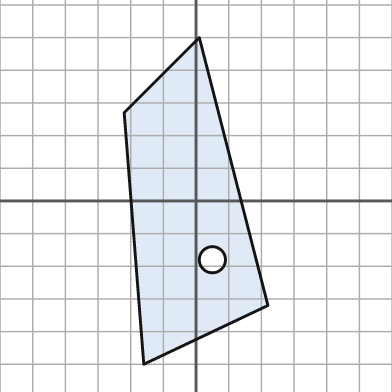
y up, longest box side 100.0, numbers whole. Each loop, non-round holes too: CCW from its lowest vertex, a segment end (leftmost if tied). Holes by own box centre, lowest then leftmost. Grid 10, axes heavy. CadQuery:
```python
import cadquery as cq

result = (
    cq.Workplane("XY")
    .moveTo(-16.0, -50.0)
    .lineTo(22.0, -32.0)
    .lineTo(1.0, 50.0)
    .lineTo(-22.0, 27.0)
    .close()
    .moveTo(5.0, -18.0)
    .circle(4.0)
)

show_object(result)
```